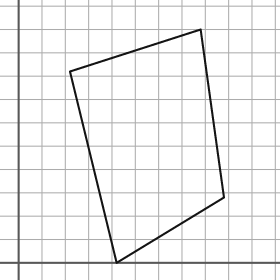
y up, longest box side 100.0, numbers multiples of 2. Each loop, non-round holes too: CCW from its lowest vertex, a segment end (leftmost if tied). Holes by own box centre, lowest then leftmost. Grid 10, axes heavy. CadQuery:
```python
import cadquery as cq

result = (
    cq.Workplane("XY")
    .moveTo(42.0, 0.0)
    .lineTo(88.0, 28.0)
    .lineTo(78.0, 100.0)
    .lineTo(22.0, 82.0)
    .close()
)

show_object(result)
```